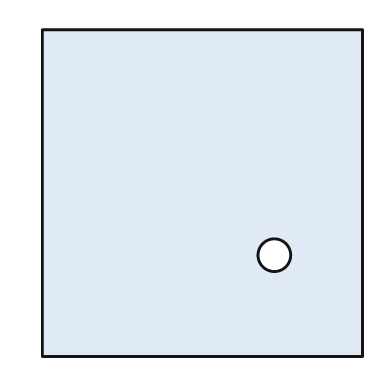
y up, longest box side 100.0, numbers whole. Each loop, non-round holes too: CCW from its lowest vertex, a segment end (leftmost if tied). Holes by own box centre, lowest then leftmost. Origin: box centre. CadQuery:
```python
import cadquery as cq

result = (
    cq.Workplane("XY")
    .moveTo(-49.0, -50.0)
    .lineTo(49.0, -50.0)
    .lineTo(49.0, 50.0)
    .lineTo(-49.0, 50.0)
    .close()
    .moveTo(22.0, -19.0)
    .circle(5.0)
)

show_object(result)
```